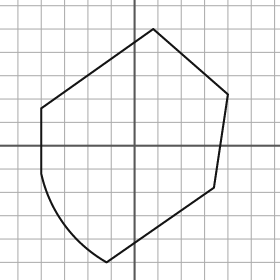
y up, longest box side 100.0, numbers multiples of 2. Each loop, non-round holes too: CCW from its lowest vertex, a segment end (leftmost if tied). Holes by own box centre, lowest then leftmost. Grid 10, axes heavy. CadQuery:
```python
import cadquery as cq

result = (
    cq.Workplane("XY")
    .moveTo(-12.0, -50.0)
    .lineTo(34.0, -18.0)
    .lineTo(40.0, 22.0)
    .lineTo(8.0, 50.0)
    .lineTo(-40.0, 16.0)
    .lineTo(-40.0, -12.0)
    .threePointArc((-30.0, -34.0), (-12.0, -50.0))
    .close()
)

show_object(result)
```